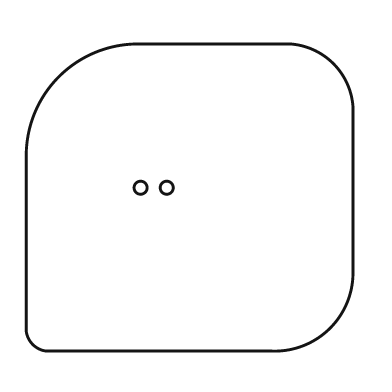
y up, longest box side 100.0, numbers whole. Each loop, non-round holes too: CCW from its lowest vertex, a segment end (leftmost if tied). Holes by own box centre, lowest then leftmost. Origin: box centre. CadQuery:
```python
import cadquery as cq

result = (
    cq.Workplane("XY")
    .moveTo(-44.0, -47.0)
    .lineTo(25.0, -47.0)
    .threePointArc((43.0, -40.0), (50.0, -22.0))
    .lineTo(50.0, 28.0)
    .threePointArc((44.0, 41.0), (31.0, 47.0))
    .lineTo(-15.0, 47.0)
    .threePointArc((-40.0, 37.0), (-50.0, 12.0))
    .lineTo(-50.0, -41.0)
    .threePointArc((-48.0, -45.0), (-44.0, -47.0))
    .close()
    .moveTo(-15.0, 3.0)
    .circle(2.0)
    .moveTo(-7.0, 3.0)
    .circle(2.0)
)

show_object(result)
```